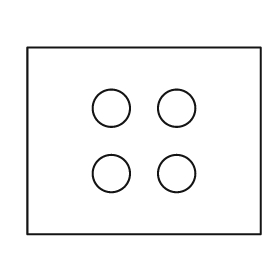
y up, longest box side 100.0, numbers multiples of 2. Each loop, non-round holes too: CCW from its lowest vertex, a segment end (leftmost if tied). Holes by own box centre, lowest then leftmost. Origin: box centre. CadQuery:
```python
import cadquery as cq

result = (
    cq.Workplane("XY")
    .moveTo(-50.0, -40.0)
    .lineTo(50.0, -40.0)
    .lineTo(50.0, 40.0)
    .lineTo(-50.0, 40.0)
    .close()
    .moveTo(-14.0, -14.0)
    .circle(8.0)
    .moveTo(14.0, -14.0)
    .circle(8.0)
    .moveTo(-14.0, 14.0)
    .circle(8.0)
    .moveTo(14.0, 14.0)
    .circle(8.0)
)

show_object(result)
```